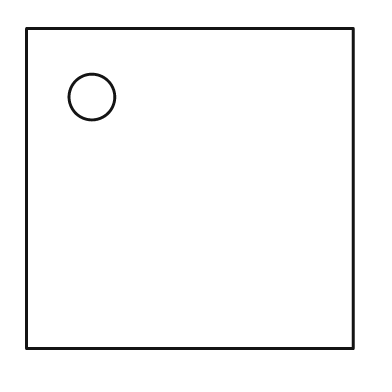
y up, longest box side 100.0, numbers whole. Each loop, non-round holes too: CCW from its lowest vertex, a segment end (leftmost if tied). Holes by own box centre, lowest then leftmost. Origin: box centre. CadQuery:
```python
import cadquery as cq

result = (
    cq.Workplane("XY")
    .moveTo(-50.0, -49.0)
    .lineTo(50.0, -49.0)
    .lineTo(50.0, 49.0)
    .lineTo(-50.0, 49.0)
    .close()
    .moveTo(-30.0, 28.0)
    .circle(7.0)
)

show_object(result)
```